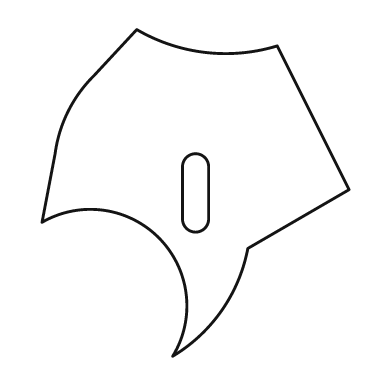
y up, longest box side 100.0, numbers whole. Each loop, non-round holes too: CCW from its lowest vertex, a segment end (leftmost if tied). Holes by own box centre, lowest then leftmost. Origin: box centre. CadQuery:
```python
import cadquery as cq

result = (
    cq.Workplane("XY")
    .moveTo(-7.0, -50.0)
    .threePointArc((8.0, -36.0), (16.0, -17.0))
    .lineTo(47.0, 1.0)
    .lineTo(25.0, 45.0)
    .threePointArc((3.0, 43.0), (-18.0, 50.0))
    .lineTo(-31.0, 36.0)
    .threePointArc((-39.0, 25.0), (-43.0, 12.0))
    .lineTo(-47.0, -9.0)
    .threePointArc((-11.0, -14.0), (-7.0, -50.0))
    .close()
    .moveTo(-4.0, -8.0)
    .threePointArc((0.0, -12.0), (4.0, -8.0))
    .lineTo(4.0, 8.0)
    .threePointArc((0.0, 12.0), (-4.0, 8.0))
    .close()
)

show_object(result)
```